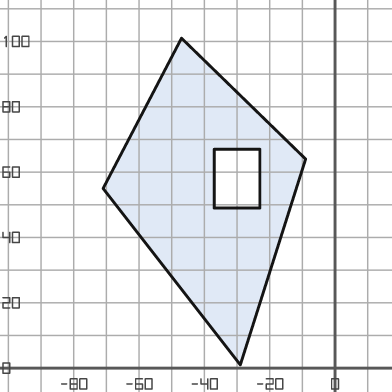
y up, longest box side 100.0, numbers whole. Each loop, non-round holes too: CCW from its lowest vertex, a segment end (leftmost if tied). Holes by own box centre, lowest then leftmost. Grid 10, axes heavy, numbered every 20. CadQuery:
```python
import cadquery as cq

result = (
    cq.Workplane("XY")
    .moveTo(-29.0, 1.0)
    .lineTo(-9.0, 64.0)
    .lineTo(-47.0, 101.0)
    .lineTo(-71.0, 55.0)
    .close()
    .moveTo(-37.0, 49.0)
    .lineTo(-23.0, 49.0)
    .lineTo(-23.0, 67.0)
    .lineTo(-37.0, 67.0)
    .close()
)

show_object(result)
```